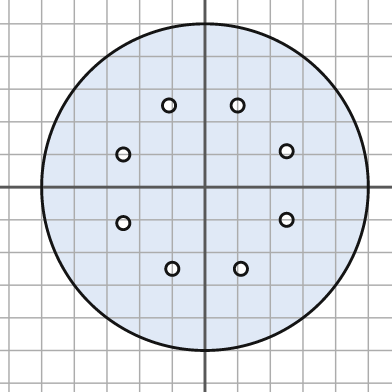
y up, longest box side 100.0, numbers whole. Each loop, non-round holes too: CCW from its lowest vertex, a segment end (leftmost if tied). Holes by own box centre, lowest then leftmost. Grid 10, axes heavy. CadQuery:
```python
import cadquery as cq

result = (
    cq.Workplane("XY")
    .moveTo(0.0, 0.0)
    .circle(50.0)
    .moveTo(-10.0, -25.0)
    .circle(2.0)
    .moveTo(11.0, -25.0)
    .circle(2.0)
    .moveTo(-25.0, -11.0)
    .circle(2.0)
    .moveTo(25.0, -10.0)
    .circle(2.0)
    .moveTo(-25.0, 10.0)
    .circle(2.0)
    .moveTo(25.0, 11.0)
    .circle(2.0)
    .moveTo(-11.0, 25.0)
    .circle(2.0)
    .moveTo(10.0, 25.0)
    .circle(2.0)
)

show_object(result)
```